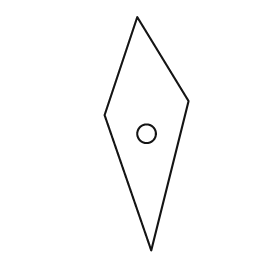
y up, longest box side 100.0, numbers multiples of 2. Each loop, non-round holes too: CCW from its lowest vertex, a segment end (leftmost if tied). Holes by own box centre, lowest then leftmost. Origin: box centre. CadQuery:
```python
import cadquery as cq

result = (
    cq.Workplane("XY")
    .moveTo(2.0, -50.0)
    .lineTo(18.0, 14.0)
    .lineTo(-4.0, 50.0)
    .lineTo(-18.0, 8.0)
    .close()
    .moveTo(0.0, 0.0)
    .circle(4.0)
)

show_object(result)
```